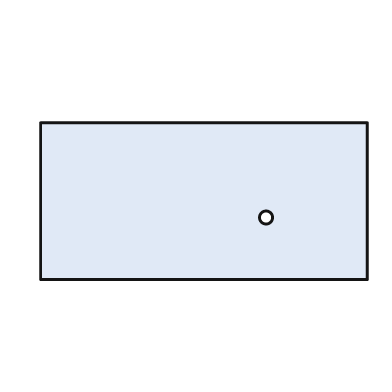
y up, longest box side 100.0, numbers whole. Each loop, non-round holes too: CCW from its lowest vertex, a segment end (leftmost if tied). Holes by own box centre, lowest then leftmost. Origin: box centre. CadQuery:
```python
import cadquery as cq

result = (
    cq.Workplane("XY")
    .moveTo(-50.0, -24.0)
    .lineTo(50.0, -24.0)
    .lineTo(50.0, 24.0)
    .lineTo(-50.0, 24.0)
    .close()
    .moveTo(19.0, -5.0)
    .circle(2.0)
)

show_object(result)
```